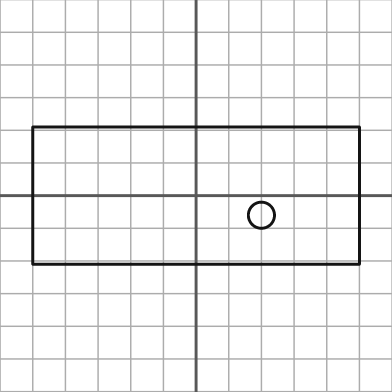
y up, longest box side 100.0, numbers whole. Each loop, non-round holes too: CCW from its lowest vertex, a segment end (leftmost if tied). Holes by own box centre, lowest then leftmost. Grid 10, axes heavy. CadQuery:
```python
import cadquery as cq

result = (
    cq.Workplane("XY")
    .moveTo(-50.0, -21.0)
    .lineTo(50.0, -21.0)
    .lineTo(50.0, 21.0)
    .lineTo(-50.0, 21.0)
    .close()
    .moveTo(20.0, -6.0)
    .circle(4.0)
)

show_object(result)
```